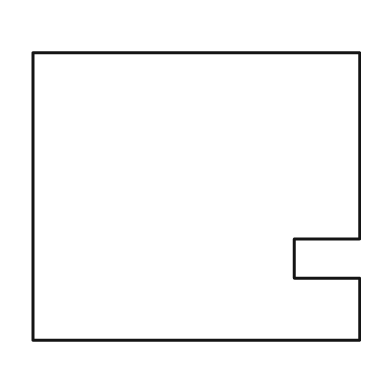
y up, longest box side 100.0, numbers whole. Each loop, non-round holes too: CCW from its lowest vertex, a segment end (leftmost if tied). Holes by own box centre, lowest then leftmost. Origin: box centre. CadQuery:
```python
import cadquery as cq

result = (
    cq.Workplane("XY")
    .moveTo(-50.0, -44.0)
    .lineTo(50.0, -44.0)
    .lineTo(50.0, -25.0)
    .lineTo(30.0, -25.0)
    .lineTo(30.0, -13.0)
    .lineTo(50.0, -13.0)
    .lineTo(50.0, 44.0)
    .lineTo(-50.0, 44.0)
    .close()
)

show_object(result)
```